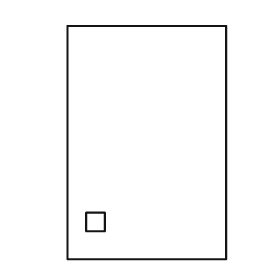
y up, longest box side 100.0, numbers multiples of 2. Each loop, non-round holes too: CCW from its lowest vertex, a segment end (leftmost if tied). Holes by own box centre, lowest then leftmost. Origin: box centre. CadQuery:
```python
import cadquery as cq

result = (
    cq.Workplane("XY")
    .moveTo(-34.0, -50.0)
    .lineTo(34.0, -50.0)
    .lineTo(34.0, 50.0)
    .lineTo(-34.0, 50.0)
    .close()
    .moveTo(-26.0, -38.0)
    .lineTo(-18.0, -38.0)
    .lineTo(-18.0, -30.0)
    .lineTo(-26.0, -30.0)
    .close()
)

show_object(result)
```